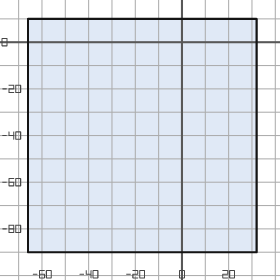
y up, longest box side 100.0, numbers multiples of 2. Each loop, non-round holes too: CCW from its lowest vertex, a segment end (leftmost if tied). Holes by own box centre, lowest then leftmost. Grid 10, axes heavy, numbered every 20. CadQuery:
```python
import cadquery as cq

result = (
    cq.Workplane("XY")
    .moveTo(-66.0, -90.0)
    .lineTo(32.0, -90.0)
    .lineTo(32.0, 10.0)
    .lineTo(-66.0, 10.0)
    .close()
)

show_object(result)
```